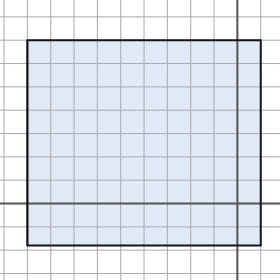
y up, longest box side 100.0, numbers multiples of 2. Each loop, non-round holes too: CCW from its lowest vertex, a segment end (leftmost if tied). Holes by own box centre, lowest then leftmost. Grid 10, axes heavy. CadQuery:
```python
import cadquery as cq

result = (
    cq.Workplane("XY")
    .moveTo(-90.0, -18.0)
    .lineTo(10.0, -18.0)
    .lineTo(10.0, 70.0)
    .lineTo(-90.0, 70.0)
    .close()
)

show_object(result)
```